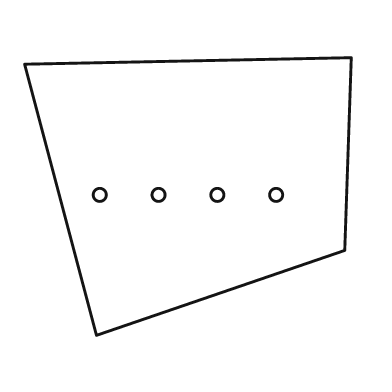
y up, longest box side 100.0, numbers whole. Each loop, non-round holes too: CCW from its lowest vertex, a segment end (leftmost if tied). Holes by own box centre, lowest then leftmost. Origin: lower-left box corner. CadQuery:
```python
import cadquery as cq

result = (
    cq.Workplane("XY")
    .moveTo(22.0, 0.0)
    .lineTo(98.0, 26.0)
    .lineTo(100.0, 85.0)
    .lineTo(0.0, 83.0)
    .close()
    .moveTo(23.0, 43.0)
    .circle(2.0)
    .moveTo(41.0, 43.0)
    .circle(2.0)
    .moveTo(59.0, 43.0)
    .circle(2.0)
    .moveTo(77.0, 43.0)
    .circle(2.0)
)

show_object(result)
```